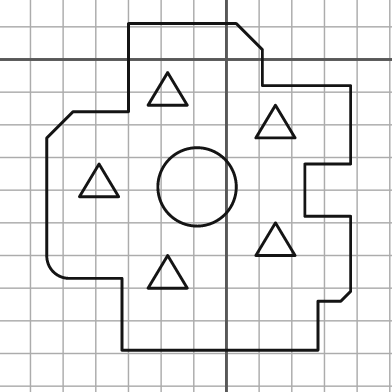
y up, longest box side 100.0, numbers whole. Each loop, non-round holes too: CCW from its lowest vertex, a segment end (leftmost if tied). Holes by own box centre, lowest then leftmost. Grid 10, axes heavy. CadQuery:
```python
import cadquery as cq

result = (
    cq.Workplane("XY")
    .moveTo(-32.0, -89.0)
    .lineTo(28.0, -89.0)
    .lineTo(28.0, -74.0)
    .lineTo(35.0, -74.0)
    .lineTo(38.0, -71.0)
    .lineTo(38.0, -48.0)
    .lineTo(24.0, -48.0)
    .lineTo(24.0, -32.0)
    .lineTo(38.0, -32.0)
    .lineTo(38.0, -8.0)
    .lineTo(11.0, -8.0)
    .lineTo(11.0, 3.0)
    .lineTo(3.0, 11.0)
    .lineTo(-30.0, 11.0)
    .lineTo(-30.0, -16.0)
    .lineTo(-47.0, -16.0)
    .lineTo(-55.0, -24.0)
    .lineTo(-55.0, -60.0)
    .threePointArc((-53.0, -65.0), (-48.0, -67.0))
    .lineTo(-32.0, -67.0)
    .close()
    .moveTo(-24.0, -70.0)
    .lineTo(-12.0, -70.0)
    .lineTo(-18.0, -60.0)
    .close()
    .moveTo(9.0, -60.0)
    .lineTo(21.0, -60.0)
    .lineTo(15.0, -50.0)
    .close()
    .moveTo(-9.0, -39.0)
    .circle(12.0)
    .moveTo(-45.0, -42.0)
    .lineTo(-33.0, -42.0)
    .lineTo(-39.0, -32.0)
    .close()
    .moveTo(9.0, -24.0)
    .lineTo(21.0, -24.0)
    .lineTo(15.0, -14.0)
    .close()
    .moveTo(-24.0, -14.0)
    .lineTo(-12.0, -14.0)
    .lineTo(-18.0, -4.0)
    .close()
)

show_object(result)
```